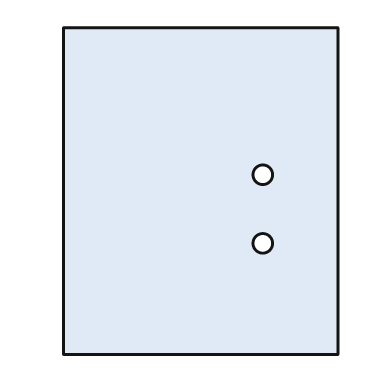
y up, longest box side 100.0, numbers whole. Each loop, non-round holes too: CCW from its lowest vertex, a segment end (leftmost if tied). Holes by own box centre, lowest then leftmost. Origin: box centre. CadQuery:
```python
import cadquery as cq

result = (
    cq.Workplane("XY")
    .moveTo(-42.0, -50.0)
    .lineTo(42.0, -50.0)
    .lineTo(42.0, 50.0)
    .lineTo(-42.0, 50.0)
    .close()
    .moveTo(19.0, -16.0)
    .circle(3.0)
    .moveTo(19.0, 5.0)
    .circle(3.0)
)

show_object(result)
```